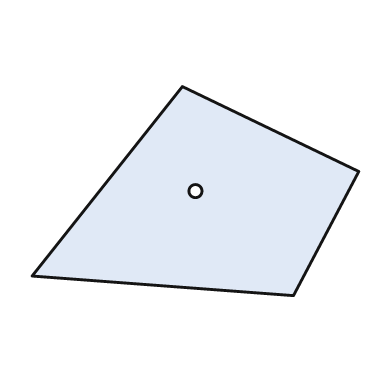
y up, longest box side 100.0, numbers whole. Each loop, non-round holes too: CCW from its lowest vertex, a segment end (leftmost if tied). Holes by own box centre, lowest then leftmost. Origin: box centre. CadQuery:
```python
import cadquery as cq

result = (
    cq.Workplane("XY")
    .moveTo(30.0, -32.0)
    .lineTo(50.0, 6.0)
    .lineTo(-4.0, 32.0)
    .lineTo(-50.0, -26.0)
    .close()
    .moveTo(0.0, 0.0)
    .circle(2.0)
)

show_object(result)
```